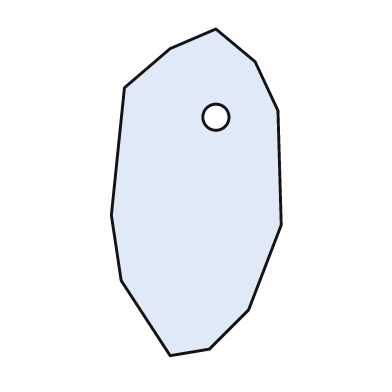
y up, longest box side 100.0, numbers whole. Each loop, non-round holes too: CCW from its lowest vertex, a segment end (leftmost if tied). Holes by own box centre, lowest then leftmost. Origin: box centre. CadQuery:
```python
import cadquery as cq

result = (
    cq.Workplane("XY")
    .moveTo(-8.0, -50.0)
    .lineTo(4.0, -48.0)
    .lineTo(16.0, -36.0)
    .lineTo(26.0, -10.0)
    .lineTo(25.0, 25.0)
    .lineTo(18.0, 40.0)
    .lineTo(6.0, 50.0)
    .lineTo(-8.0, 44.0)
    .lineTo(-22.0, 32.0)
    .lineTo(-26.0, -7.0)
    .lineTo(-23.0, -27.0)
    .close()
    .moveTo(6.0, 23.0)
    .circle(4.0)
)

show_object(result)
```